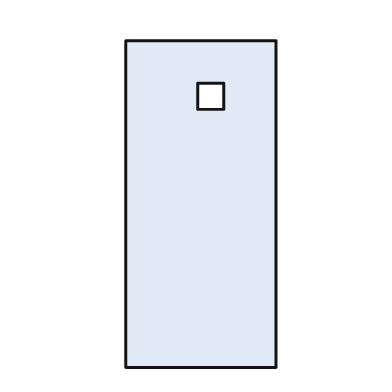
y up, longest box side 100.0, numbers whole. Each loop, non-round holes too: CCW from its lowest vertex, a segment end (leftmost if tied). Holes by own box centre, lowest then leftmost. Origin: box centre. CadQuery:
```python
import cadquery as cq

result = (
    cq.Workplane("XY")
    .moveTo(-23.0, -50.0)
    .lineTo(23.0, -50.0)
    .lineTo(23.0, 50.0)
    .lineTo(-23.0, 50.0)
    .close()
    .moveTo(-1.0, 29.0)
    .lineTo(7.0, 29.0)
    .lineTo(7.0, 37.0)
    .lineTo(-1.0, 37.0)
    .close()
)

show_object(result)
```